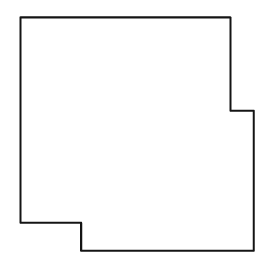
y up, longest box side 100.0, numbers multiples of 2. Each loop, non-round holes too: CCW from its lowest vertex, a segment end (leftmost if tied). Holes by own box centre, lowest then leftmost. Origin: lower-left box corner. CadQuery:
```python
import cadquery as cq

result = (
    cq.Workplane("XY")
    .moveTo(26.0, 0.0)
    .lineTo(100.0, 0.0)
    .lineTo(100.0, 60.0)
    .lineTo(90.0, 60.0)
    .lineTo(90.0, 100.0)
    .lineTo(0.0, 100.0)
    .lineTo(0.0, 12.0)
    .lineTo(26.0, 12.0)
    .close()
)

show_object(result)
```